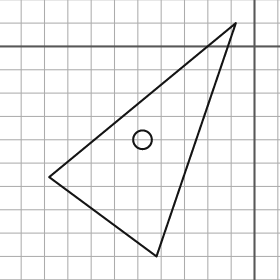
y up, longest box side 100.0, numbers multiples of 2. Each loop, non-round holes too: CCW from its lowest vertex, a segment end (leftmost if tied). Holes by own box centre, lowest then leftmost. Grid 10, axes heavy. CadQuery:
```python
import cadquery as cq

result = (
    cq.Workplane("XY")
    .moveTo(-42.0, -90.0)
    .lineTo(-8.0, 10.0)
    .lineTo(-88.0, -56.0)
    .close()
    .moveTo(-48.0, -40.0)
    .circle(4.0)
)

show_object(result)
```